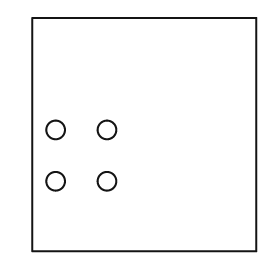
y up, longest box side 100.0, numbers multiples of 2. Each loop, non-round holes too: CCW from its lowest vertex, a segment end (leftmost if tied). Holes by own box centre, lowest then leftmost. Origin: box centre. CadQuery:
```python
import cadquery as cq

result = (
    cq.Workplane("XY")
    .moveTo(-48.0, -50.0)
    .lineTo(48.0, -50.0)
    .lineTo(48.0, 50.0)
    .lineTo(-48.0, 50.0)
    .close()
    .moveTo(-38.0, -20.0)
    .circle(4.0)
    .moveTo(-16.0, -20.0)
    .circle(4.0)
    .moveTo(-38.0, 2.0)
    .circle(4.0)
    .moveTo(-16.0, 2.0)
    .circle(4.0)
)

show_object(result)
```